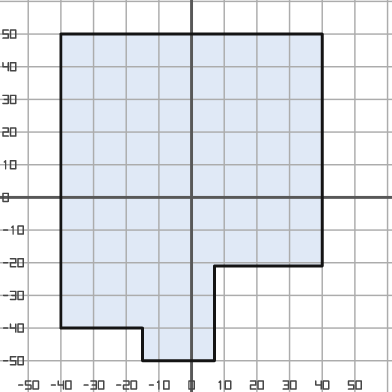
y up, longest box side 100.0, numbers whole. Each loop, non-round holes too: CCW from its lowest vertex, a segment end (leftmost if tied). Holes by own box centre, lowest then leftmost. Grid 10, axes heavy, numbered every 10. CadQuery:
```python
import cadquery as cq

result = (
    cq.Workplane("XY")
    .moveTo(-15.0, -50.0)
    .lineTo(7.0, -50.0)
    .lineTo(7.0, -21.0)
    .lineTo(40.0, -21.0)
    .lineTo(40.0, 50.0)
    .lineTo(-40.0, 50.0)
    .lineTo(-40.0, -40.0)
    .lineTo(-15.0, -40.0)
    .close()
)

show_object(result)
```